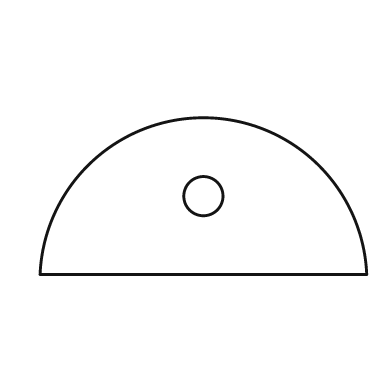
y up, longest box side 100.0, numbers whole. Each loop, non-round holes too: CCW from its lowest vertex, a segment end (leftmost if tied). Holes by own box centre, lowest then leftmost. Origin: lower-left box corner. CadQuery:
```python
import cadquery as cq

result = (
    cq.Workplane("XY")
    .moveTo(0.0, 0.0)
    .lineTo(100.0, 0.0)
    .threePointArc((50.0, 48.0), (0.0, 0.0))
    .close()
    .moveTo(50.0, 24.0)
    .circle(6.0)
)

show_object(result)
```